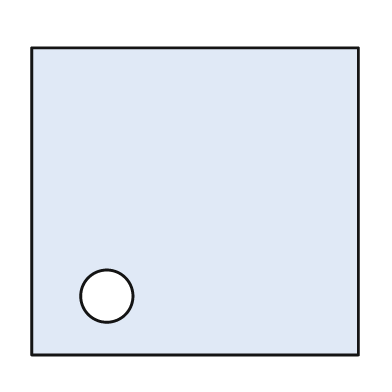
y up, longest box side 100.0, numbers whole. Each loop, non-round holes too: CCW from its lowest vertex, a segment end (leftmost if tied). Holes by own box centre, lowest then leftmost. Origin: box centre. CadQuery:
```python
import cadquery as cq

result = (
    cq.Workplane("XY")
    .moveTo(-50.0, -47.0)
    .lineTo(50.0, -47.0)
    .lineTo(50.0, 47.0)
    .lineTo(-50.0, 47.0)
    .close()
    .moveTo(-27.0, -29.0)
    .circle(8.0)
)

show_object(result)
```